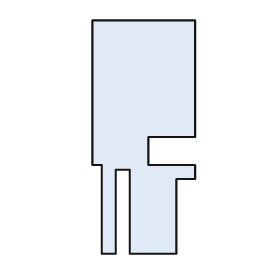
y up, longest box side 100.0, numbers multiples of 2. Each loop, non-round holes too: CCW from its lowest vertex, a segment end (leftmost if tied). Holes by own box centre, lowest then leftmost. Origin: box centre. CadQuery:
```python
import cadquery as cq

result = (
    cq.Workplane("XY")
    .moveTo(-18.0, -50.0)
    .lineTo(-12.0, -50.0)
    .lineTo(-12.0, -14.0)
    .lineTo(-6.0, -14.0)
    .lineTo(-6.0, -50.0)
    .lineTo(14.0, -50.0)
    .lineTo(14.0, -18.0)
    .lineTo(22.0, -18.0)
    .lineTo(22.0, -12.0)
    .lineTo(2.0, -12.0)
    .lineTo(2.0, 0.0)
    .lineTo(22.0, 0.0)
    .lineTo(22.0, 50.0)
    .lineTo(-22.0, 50.0)
    .lineTo(-22.0, -12.0)
    .lineTo(-18.0, -12.0)
    .close()
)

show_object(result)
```